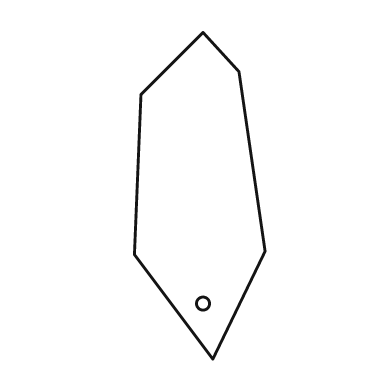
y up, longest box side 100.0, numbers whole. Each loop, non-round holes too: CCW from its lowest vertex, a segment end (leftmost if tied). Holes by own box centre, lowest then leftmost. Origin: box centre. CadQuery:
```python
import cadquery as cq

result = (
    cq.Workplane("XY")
    .moveTo(4.0, -50.0)
    .lineTo(20.0, -17.0)
    .lineTo(12.0, 38.0)
    .lineTo(1.0, 50.0)
    .lineTo(-18.0, 31.0)
    .lineTo(-20.0, -18.0)
    .close()
    .moveTo(1.0, -33.0)
    .circle(2.0)
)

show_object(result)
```